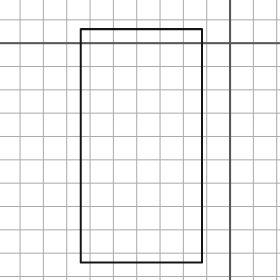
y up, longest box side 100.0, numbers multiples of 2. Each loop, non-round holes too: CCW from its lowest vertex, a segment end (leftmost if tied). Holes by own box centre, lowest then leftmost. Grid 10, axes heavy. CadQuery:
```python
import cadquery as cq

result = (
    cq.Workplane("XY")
    .moveTo(-64.0, -94.0)
    .lineTo(-12.0, -94.0)
    .lineTo(-12.0, 6.0)
    .lineTo(-64.0, 6.0)
    .close()
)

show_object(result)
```